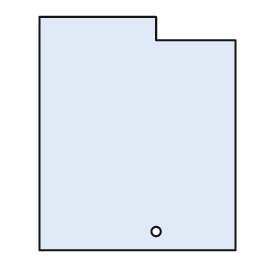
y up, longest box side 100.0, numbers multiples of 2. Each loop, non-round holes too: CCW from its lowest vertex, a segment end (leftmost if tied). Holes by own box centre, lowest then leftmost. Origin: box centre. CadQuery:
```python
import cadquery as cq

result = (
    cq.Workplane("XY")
    .moveTo(-42.0, -50.0)
    .lineTo(42.0, -50.0)
    .lineTo(42.0, 40.0)
    .lineTo(8.0, 40.0)
    .lineTo(8.0, 50.0)
    .lineTo(-42.0, 50.0)
    .close()
    .moveTo(8.0, -42.0)
    .circle(2.0)
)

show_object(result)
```